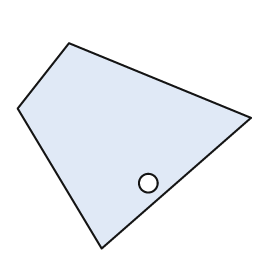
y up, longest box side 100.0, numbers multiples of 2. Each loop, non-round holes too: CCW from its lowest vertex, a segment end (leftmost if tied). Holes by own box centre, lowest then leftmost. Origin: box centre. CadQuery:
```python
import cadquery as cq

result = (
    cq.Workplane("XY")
    .moveTo(-14.0, -44.0)
    .lineTo(50.0, 12.0)
    .lineTo(-28.0, 44.0)
    .lineTo(-50.0, 16.0)
    .close()
    .moveTo(6.0, -16.0)
    .circle(4.0)
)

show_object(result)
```